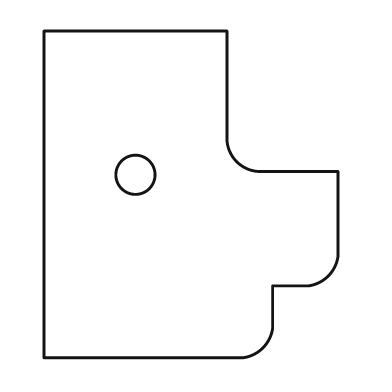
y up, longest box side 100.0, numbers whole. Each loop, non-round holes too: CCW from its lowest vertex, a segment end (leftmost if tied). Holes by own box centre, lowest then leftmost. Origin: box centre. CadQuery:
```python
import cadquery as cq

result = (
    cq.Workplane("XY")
    .moveTo(-45.0, -50.0)
    .lineTo(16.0, -50.0)
    .threePointArc((22.0, -47.0), (25.0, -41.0))
    .lineTo(25.0, -28.0)
    .lineTo(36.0, -28.0)
    .threePointArc((42.0, -25.0), (45.0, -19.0))
    .lineTo(45.0, 7.0)
    .lineTo(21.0, 7.0)
    .threePointArc((14.0, 10.0), (11.0, 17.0))
    .lineTo(11.0, 50.0)
    .lineTo(-45.0, 50.0)
    .close()
    .moveTo(-17.0, 6.0)
    .circle(6.0)
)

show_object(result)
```